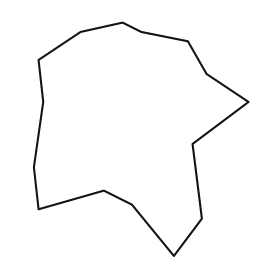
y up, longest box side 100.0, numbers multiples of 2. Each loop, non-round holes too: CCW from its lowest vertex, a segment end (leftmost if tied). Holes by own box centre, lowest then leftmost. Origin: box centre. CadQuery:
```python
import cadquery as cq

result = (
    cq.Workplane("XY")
    .moveTo(14.0, -50.0)
    .lineTo(26.0, -34.0)
    .lineTo(22.0, -2.0)
    .lineTo(46.0, 16.0)
    .lineTo(28.0, 28.0)
    .lineTo(20.0, 42.0)
    .lineTo(0.0, 46.0)
    .lineTo(-8.0, 50.0)
    .lineTo(-26.0, 46.0)
    .lineTo(-44.0, 34.0)
    .lineTo(-42.0, 16.0)
    .lineTo(-46.0, -12.0)
    .lineTo(-44.0, -30.0)
    .lineTo(-16.0, -22.0)
    .lineTo(-4.0, -28.0)
    .close()
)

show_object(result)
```